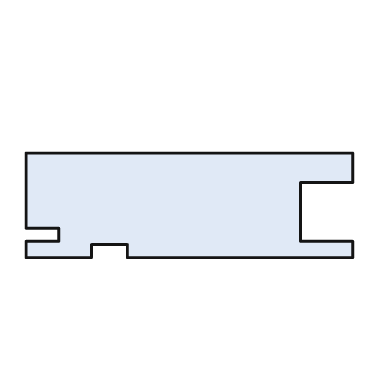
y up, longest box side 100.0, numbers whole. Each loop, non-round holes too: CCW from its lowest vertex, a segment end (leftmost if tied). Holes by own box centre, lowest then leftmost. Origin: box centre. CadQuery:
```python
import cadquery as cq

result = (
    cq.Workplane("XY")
    .moveTo(-50.0, -16.0)
    .lineTo(-30.0, -16.0)
    .lineTo(-30.0, -12.0)
    .lineTo(-19.0, -12.0)
    .lineTo(-19.0, -16.0)
    .lineTo(50.0, -16.0)
    .lineTo(50.0, -11.0)
    .lineTo(34.0, -11.0)
    .lineTo(34.0, 7.0)
    .lineTo(50.0, 7.0)
    .lineTo(50.0, 16.0)
    .lineTo(-50.0, 16.0)
    .lineTo(-50.0, -7.0)
    .lineTo(-40.0, -7.0)
    .lineTo(-40.0, -11.0)
    .lineTo(-50.0, -11.0)
    .close()
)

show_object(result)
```